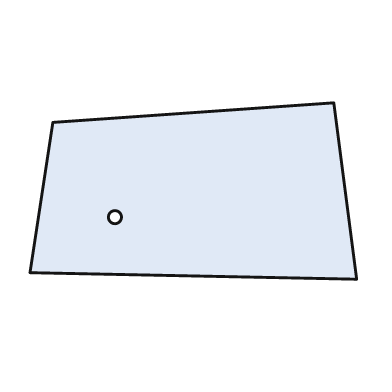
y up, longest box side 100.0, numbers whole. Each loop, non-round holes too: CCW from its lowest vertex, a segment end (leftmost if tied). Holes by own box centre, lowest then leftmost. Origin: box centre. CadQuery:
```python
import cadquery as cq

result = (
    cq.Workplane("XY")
    .moveTo(50.0, -27.0)
    .lineTo(43.0, 27.0)
    .lineTo(-43.0, 21.0)
    .lineTo(-50.0, -25.0)
    .close()
    .moveTo(-24.0, -8.0)
    .circle(2.0)
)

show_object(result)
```